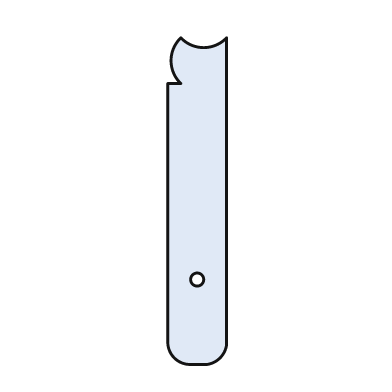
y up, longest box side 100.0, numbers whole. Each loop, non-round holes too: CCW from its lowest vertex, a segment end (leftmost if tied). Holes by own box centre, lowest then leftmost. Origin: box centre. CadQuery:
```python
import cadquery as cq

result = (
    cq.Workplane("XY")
    .moveTo(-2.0, -50.0)
    .lineTo(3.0, -50.0)
    .threePointArc((7.0, -48.0), (9.0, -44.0))
    .lineTo(9.0, 50.0)
    .threePointArc((2.0, 47.0), (-5.0, 50.0))
    .threePointArc((-8.0, 43.0), (-5.0, 36.0))
    .lineTo(-9.0, 36.0)
    .lineTo(-9.0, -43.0)
    .threePointArc((-7.0, -48.0), (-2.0, -50.0))
    .close()
    .moveTo(0.0, -24.0)
    .circle(2.0)
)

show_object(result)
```